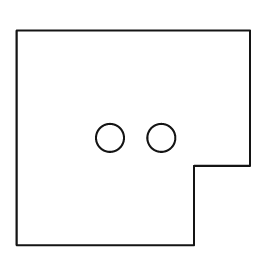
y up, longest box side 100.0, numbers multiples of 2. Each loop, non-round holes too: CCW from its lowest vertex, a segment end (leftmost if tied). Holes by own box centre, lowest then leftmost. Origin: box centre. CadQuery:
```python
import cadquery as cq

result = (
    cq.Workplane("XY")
    .moveTo(-50.0, -46.0)
    .lineTo(26.0, -46.0)
    .lineTo(26.0, -12.0)
    .lineTo(50.0, -12.0)
    .lineTo(50.0, 46.0)
    .lineTo(-50.0, 46.0)
    .close()
    .moveTo(-10.0, 0.0)
    .circle(6.0)
    .moveTo(12.0, 0.0)
    .circle(6.0)
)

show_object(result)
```